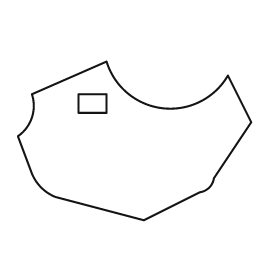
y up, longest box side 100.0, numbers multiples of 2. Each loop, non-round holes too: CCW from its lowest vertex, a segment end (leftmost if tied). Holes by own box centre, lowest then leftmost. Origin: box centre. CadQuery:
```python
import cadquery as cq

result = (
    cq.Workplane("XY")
    .moveTo(4.0, -34.0)
    .lineTo(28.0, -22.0)
    .threePointArc((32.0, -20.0), (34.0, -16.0))
    .lineTo(50.0, 8.0)
    .lineTo(40.0, 28.0)
    .threePointArc((12.0, 14.0), (-12.0, 34.0))
    .lineTo(-44.0, 20.0)
    .threePointArc((-44.0, 10.0), (-50.0, 2.0))
    .lineTo(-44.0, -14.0)
    .threePointArc((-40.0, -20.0), (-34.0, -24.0))
    .close()
    .moveTo(-24.0, 12.0)
    .lineTo(-12.0, 12.0)
    .lineTo(-12.0, 20.0)
    .lineTo(-24.0, 20.0)
    .close()
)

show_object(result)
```